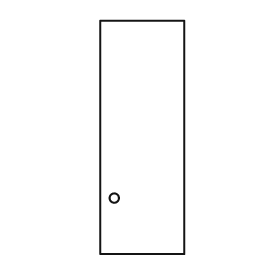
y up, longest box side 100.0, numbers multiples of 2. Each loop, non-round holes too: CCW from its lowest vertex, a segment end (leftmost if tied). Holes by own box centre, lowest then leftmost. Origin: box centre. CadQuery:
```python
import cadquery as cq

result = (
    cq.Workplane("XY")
    .moveTo(-18.0, -50.0)
    .lineTo(18.0, -50.0)
    .lineTo(18.0, 50.0)
    .lineTo(-18.0, 50.0)
    .close()
    .moveTo(-12.0, -26.0)
    .circle(2.0)
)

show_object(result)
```